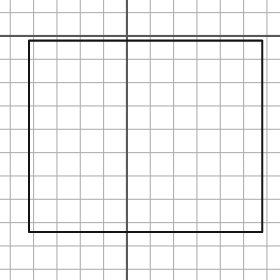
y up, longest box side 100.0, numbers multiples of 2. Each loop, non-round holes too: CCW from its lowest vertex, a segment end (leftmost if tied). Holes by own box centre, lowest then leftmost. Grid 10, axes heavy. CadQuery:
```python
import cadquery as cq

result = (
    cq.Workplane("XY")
    .moveTo(-42.0, -84.0)
    .lineTo(58.0, -84.0)
    .lineTo(58.0, -2.0)
    .lineTo(-42.0, -2.0)
    .close()
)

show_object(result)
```